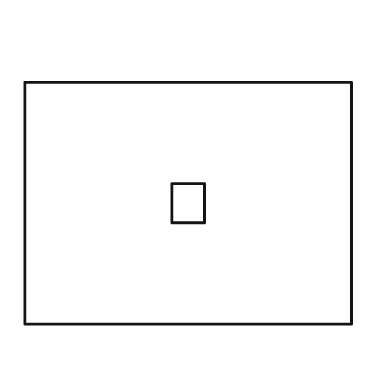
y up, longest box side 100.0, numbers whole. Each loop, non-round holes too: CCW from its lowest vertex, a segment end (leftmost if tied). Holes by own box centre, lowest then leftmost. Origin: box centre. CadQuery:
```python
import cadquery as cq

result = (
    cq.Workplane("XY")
    .moveTo(-50.0, -37.0)
    .lineTo(50.0, -37.0)
    .lineTo(50.0, 37.0)
    .lineTo(-50.0, 37.0)
    .close()
    .moveTo(-5.0, -6.0)
    .lineTo(5.0, -6.0)
    .lineTo(5.0, 6.0)
    .lineTo(-5.0, 6.0)
    .close()
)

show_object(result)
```